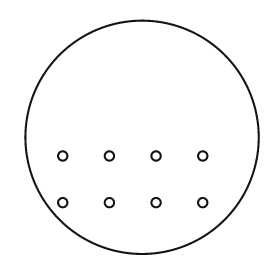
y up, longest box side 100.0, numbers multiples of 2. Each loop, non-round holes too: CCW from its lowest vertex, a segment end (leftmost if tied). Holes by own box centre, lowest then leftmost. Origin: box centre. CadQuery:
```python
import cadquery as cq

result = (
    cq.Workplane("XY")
    .moveTo(0.0, 0.0)
    .circle(50.0)
    .moveTo(-34.0, -28.0)
    .circle(2.0)
    .moveTo(-14.0, -28.0)
    .circle(2.0)
    .moveTo(6.0, -28.0)
    .circle(2.0)
    .moveTo(26.0, -28.0)
    .circle(2.0)
    .moveTo(-34.0, -8.0)
    .circle(2.0)
    .moveTo(-14.0, -8.0)
    .circle(2.0)
    .moveTo(6.0, -8.0)
    .circle(2.0)
    .moveTo(26.0, -8.0)
    .circle(2.0)
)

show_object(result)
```